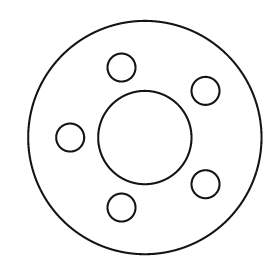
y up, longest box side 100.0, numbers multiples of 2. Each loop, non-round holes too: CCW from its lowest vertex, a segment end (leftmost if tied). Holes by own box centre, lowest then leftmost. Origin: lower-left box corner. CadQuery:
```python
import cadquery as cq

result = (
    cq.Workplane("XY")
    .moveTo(50.0, 50.0)
    .circle(50.0)
    .moveTo(40.0, 20.0)
    .circle(6.0)
    .moveTo(76.0, 30.0)
    .circle(6.0)
    .moveTo(18.0, 50.0)
    .circle(6.0)
    .moveTo(50.0, 50.0)
    .circle(20.0)
    .moveTo(76.0, 70.0)
    .circle(6.0)
    .moveTo(40.0, 80.0)
    .circle(6.0)
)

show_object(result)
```